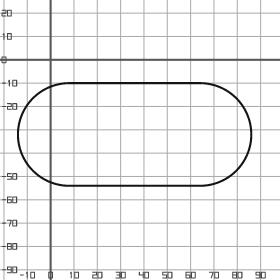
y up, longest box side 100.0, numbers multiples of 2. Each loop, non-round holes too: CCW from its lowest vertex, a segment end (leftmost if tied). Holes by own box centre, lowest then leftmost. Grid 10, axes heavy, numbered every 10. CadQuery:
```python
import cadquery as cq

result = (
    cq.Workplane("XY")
    .moveTo(8.0, -54.0)
    .lineTo(64.0, -54.0)
    .threePointArc((86.0, -32.0), (64.0, -10.0))
    .lineTo(8.0, -10.0)
    .threePointArc((-14.0, -32.0), (8.0, -54.0))
    .close()
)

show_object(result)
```